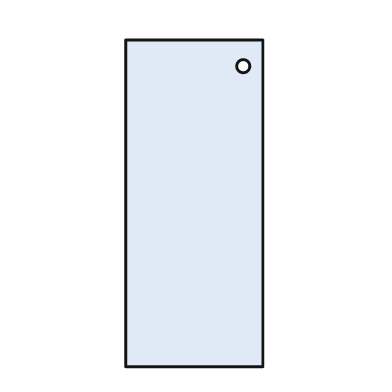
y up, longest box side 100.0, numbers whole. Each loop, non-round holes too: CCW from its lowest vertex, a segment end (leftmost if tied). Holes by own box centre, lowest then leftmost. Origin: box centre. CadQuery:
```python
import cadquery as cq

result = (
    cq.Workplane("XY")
    .moveTo(-21.0, -50.0)
    .lineTo(21.0, -50.0)
    .lineTo(21.0, 50.0)
    .lineTo(-21.0, 50.0)
    .close()
    .moveTo(15.0, 42.0)
    .circle(2.0)
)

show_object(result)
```